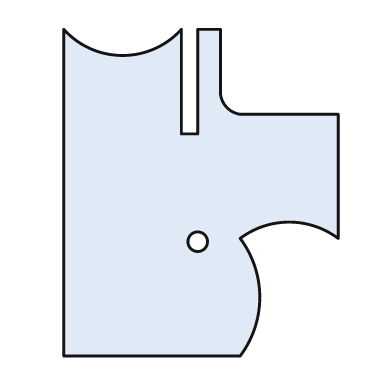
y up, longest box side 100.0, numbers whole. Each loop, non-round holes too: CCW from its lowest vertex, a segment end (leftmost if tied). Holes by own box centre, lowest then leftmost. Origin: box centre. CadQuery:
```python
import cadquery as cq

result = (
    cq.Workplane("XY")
    .moveTo(-42.0, -50.0)
    .lineTo(12.0, -50.0)
    .threePointArc((18.0, -32.0), (12.0, -14.0))
    .threePointArc((27.0, -9.0), (42.0, -14.0))
    .lineTo(42.0, 24.0)
    .lineTo(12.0, 24.0)
    .threePointArc((8.0, 26.0), (6.0, 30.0))
    .lineTo(6.0, 50.0)
    .lineTo(-1.0, 50.0)
    .lineTo(-1.0, 18.0)
    .lineTo(-6.0, 18.0)
    .lineTo(-6.0, 50.0)
    .threePointArc((-24.0, 42.0), (-42.0, 50.0))
    .close()
    .moveTo(-1.0, -15.0)
    .circle(3.0)
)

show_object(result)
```